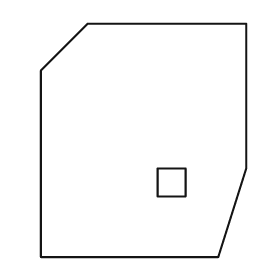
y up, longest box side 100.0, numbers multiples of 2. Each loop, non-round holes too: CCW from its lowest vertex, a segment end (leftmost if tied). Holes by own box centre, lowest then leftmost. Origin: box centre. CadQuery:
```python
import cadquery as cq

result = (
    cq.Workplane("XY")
    .moveTo(-44.0, -50.0)
    .lineTo(32.0, -50.0)
    .lineTo(44.0, -12.0)
    .lineTo(44.0, 50.0)
    .lineTo(-24.0, 50.0)
    .lineTo(-44.0, 30.0)
    .close()
    .moveTo(6.0, -24.0)
    .lineTo(18.0, -24.0)
    .lineTo(18.0, -12.0)
    .lineTo(6.0, -12.0)
    .close()
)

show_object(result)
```